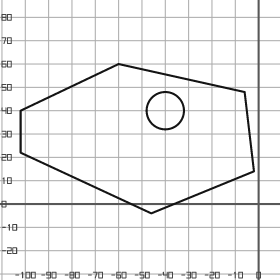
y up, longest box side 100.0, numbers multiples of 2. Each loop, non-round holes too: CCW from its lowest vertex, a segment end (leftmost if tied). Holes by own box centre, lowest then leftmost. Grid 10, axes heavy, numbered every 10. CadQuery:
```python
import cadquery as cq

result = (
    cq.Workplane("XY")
    .moveTo(-46.0, -4.0)
    .lineTo(-2.0, 14.0)
    .lineTo(-6.0, 48.0)
    .lineTo(-60.0, 60.0)
    .lineTo(-102.0, 40.0)
    .lineTo(-102.0, 22.0)
    .close()
    .moveTo(-40.0, 40.0)
    .circle(8.0)
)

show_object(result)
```